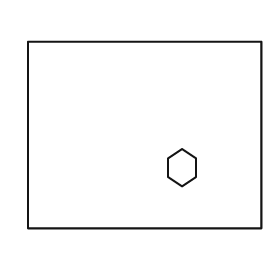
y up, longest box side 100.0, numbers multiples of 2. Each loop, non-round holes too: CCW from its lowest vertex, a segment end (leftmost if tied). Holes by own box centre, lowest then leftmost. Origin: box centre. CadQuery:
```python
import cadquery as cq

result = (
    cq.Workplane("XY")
    .moveTo(-50.0, -40.0)
    .lineTo(50.0, -40.0)
    .lineTo(50.0, 40.0)
    .lineTo(-50.0, 40.0)
    .close()
    .moveTo(16.0, -22.0)
    .lineTo(22.0, -18.0)
    .lineTo(22.0, -10.0)
    .lineTo(16.0, -6.0)
    .lineTo(10.0, -10.0)
    .lineTo(10.0, -18.0)
    .close()
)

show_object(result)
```